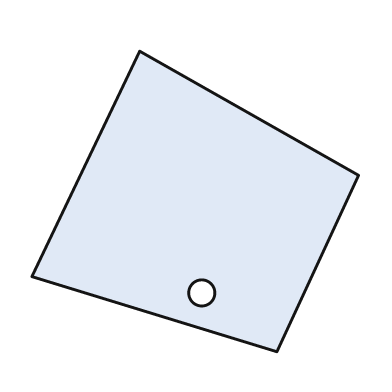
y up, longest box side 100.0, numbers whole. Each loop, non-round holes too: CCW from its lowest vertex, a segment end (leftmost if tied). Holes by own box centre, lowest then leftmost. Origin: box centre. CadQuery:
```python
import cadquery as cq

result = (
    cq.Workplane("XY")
    .moveTo(25.0, -46.0)
    .lineTo(50.0, 8.0)
    .lineTo(-17.0, 46.0)
    .lineTo(-50.0, -23.0)
    .close()
    .moveTo(2.0, -28.0)
    .circle(4.0)
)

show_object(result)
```